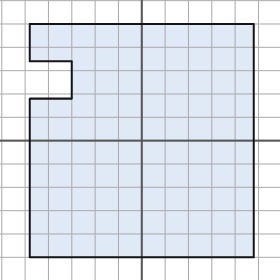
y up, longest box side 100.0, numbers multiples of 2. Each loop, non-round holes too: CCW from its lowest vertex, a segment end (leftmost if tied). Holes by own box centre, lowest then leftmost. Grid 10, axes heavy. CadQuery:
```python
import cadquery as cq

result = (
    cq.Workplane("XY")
    .moveTo(-48.0, -50.0)
    .lineTo(48.0, -50.0)
    .lineTo(48.0, 50.0)
    .lineTo(-48.0, 50.0)
    .lineTo(-48.0, 34.0)
    .lineTo(-30.0, 34.0)
    .lineTo(-30.0, 18.0)
    .lineTo(-48.0, 18.0)
    .close()
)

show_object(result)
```